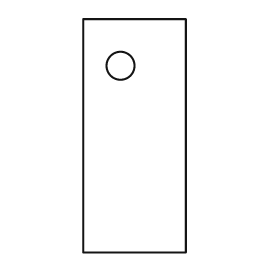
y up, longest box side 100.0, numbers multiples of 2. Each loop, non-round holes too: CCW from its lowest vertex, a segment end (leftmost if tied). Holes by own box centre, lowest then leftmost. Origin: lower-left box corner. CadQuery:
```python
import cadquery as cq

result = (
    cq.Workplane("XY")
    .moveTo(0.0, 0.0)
    .lineTo(44.0, 0.0)
    .lineTo(44.0, 100.0)
    .lineTo(0.0, 100.0)
    .close()
    .moveTo(16.0, 80.0)
    .circle(6.0)
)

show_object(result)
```